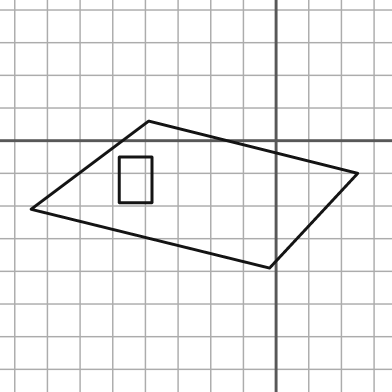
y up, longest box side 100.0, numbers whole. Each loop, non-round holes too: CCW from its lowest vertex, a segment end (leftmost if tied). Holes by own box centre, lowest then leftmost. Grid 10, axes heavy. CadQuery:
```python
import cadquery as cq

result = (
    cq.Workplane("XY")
    .moveTo(-2.0, -39.0)
    .lineTo(25.0, -10.0)
    .lineTo(-39.0, 6.0)
    .lineTo(-75.0, -21.0)
    .close()
    .moveTo(-48.0, -19.0)
    .lineTo(-38.0, -19.0)
    .lineTo(-38.0, -5.0)
    .lineTo(-48.0, -5.0)
    .close()
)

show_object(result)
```